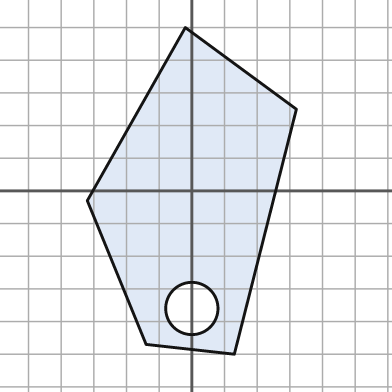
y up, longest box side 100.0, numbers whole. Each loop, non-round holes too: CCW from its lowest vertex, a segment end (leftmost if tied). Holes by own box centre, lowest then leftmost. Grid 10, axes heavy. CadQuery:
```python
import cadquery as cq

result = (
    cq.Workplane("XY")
    .moveTo(13.0, -50.0)
    .lineTo(32.0, 25.0)
    .lineTo(-2.0, 50.0)
    .lineTo(-32.0, -3.0)
    .lineTo(-14.0, -47.0)
    .close()
    .moveTo(0.0, -36.0)
    .circle(8.0)
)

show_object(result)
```